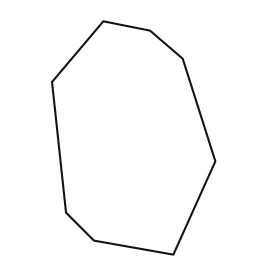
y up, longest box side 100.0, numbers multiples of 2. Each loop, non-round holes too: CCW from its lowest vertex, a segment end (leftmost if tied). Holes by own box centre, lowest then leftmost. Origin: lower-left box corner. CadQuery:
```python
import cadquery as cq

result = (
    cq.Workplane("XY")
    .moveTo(52.0, 0.0)
    .lineTo(70.0, 40.0)
    .lineTo(56.0, 84.0)
    .lineTo(42.0, 96.0)
    .lineTo(22.0, 100.0)
    .lineTo(0.0, 74.0)
    .lineTo(6.0, 18.0)
    .lineTo(18.0, 6.0)
    .close()
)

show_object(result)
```